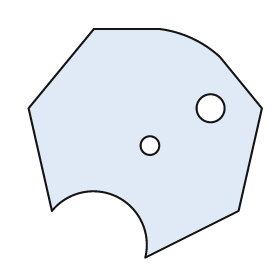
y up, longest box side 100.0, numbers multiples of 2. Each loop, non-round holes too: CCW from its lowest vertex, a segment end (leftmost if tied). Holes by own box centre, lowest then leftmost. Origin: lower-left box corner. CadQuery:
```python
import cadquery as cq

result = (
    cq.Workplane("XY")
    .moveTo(50.0, 0.0)
    .lineTo(90.0, 20.0)
    .lineTo(100.0, 64.0)
    .lineTo(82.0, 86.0)
    .threePointArc((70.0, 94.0), (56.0, 98.0))
    .lineTo(28.0, 98.0)
    .lineTo(0.0, 64.0)
    .lineTo(10.0, 20.0)
    .threePointArc((38.0, 26.0), (50.0, 0.0))
    .close()
    .moveTo(52.0, 48.0)
    .circle(4.0)
    .moveTo(78.0, 64.0)
    .circle(6.0)
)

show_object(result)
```